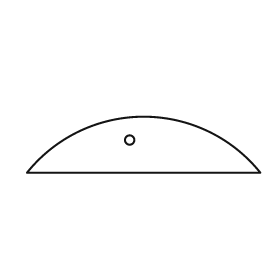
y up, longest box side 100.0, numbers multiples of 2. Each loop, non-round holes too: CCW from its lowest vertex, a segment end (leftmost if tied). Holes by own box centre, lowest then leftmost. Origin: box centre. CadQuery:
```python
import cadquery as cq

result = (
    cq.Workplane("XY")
    .moveTo(-50.0, -12.0)
    .lineTo(50.0, -12.0)
    .threePointArc((0.0, 12.0), (-50.0, -12.0))
    .close()
    .moveTo(-6.0, 2.0)
    .circle(2.0)
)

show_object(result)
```